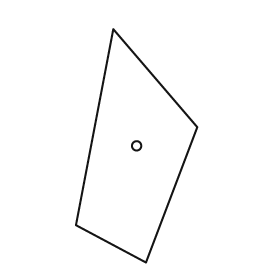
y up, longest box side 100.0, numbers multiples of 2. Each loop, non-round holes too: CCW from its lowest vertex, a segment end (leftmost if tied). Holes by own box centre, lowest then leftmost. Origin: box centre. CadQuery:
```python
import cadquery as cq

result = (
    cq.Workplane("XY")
    .moveTo(4.0, -50.0)
    .lineTo(26.0, 8.0)
    .lineTo(-10.0, 50.0)
    .lineTo(-26.0, -34.0)
    .close()
    .moveTo(0.0, 0.0)
    .circle(2.0)
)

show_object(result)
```